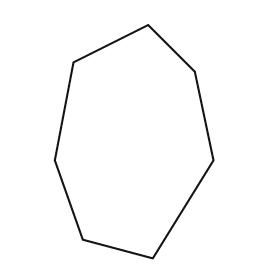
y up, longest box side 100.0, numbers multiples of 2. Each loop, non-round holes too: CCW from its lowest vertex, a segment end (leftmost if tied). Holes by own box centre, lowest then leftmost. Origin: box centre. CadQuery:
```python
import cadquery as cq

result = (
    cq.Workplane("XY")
    .moveTo(8.0, -50.0)
    .lineTo(34.0, -8.0)
    .lineTo(26.0, 30.0)
    .lineTo(6.0, 50.0)
    .lineTo(-26.0, 34.0)
    .lineTo(-34.0, -8.0)
    .lineTo(-22.0, -42.0)
    .close()
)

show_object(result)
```